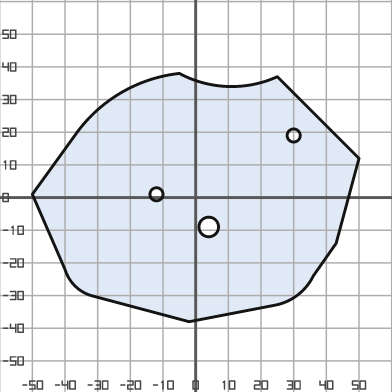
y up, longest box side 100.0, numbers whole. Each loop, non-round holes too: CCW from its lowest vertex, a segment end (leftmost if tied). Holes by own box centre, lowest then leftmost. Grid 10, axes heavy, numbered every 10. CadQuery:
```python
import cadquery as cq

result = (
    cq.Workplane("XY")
    .moveTo(-2.0, -38.0)
    .lineTo(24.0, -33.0)
    .threePointArc((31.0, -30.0), (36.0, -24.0))
    .lineTo(43.0, -14.0)
    .lineTo(50.0, 12.0)
    .lineTo(25.0, 37.0)
    .threePointArc((10.0, 34.0), (-5.0, 38.0))
    .threePointArc((-23.0, 32.0), (-37.0, 19.0))
    .lineTo(-50.0, 1.0)
    .lineTo(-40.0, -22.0)
    .threePointArc((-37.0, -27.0), (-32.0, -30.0))
    .close()
    .moveTo(4.0, -9.0)
    .circle(3.0)
    .moveTo(-12.0, 1.0)
    .circle(2.0)
    .moveTo(30.0, 19.0)
    .circle(2.0)
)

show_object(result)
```